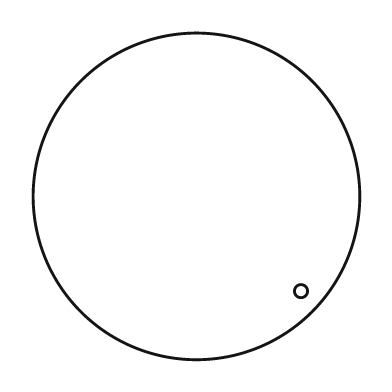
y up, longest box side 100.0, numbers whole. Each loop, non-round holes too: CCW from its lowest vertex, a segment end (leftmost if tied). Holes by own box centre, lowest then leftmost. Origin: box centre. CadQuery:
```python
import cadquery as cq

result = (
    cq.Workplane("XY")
    .moveTo(0.0, 0.0)
    .circle(50.0)
    .moveTo(32.0, -29.0)
    .circle(2.0)
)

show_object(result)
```